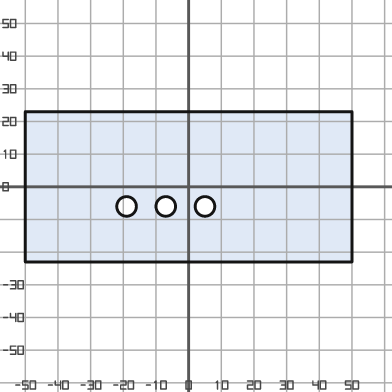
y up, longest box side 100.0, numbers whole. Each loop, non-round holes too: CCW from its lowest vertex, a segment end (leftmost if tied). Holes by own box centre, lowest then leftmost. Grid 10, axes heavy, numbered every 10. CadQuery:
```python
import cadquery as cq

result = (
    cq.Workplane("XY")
    .moveTo(-50.0, -23.0)
    .lineTo(50.0, -23.0)
    .lineTo(50.0, 23.0)
    .lineTo(-50.0, 23.0)
    .close()
    .moveTo(-19.0, -6.0)
    .circle(3.0)
    .moveTo(-7.0, -6.0)
    .circle(3.0)
    .moveTo(5.0, -6.0)
    .circle(3.0)
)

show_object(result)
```